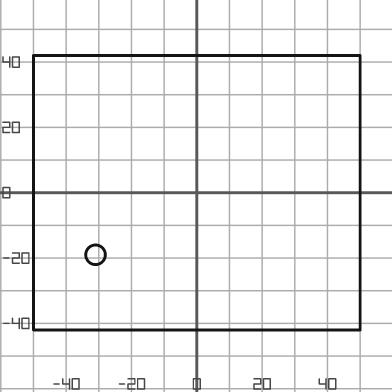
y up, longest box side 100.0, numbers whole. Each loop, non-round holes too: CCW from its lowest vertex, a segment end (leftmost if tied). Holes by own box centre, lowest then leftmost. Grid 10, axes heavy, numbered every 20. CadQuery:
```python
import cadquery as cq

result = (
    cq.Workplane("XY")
    .moveTo(-50.0, -42.0)
    .lineTo(50.0, -42.0)
    .lineTo(50.0, 42.0)
    .lineTo(-50.0, 42.0)
    .close()
    .moveTo(-31.0, -19.0)
    .circle(3.0)
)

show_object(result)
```